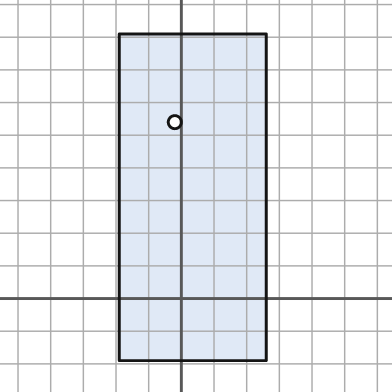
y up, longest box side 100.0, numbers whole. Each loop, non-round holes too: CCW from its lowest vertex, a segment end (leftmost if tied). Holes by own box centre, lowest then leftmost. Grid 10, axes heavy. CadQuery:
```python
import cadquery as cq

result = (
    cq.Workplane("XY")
    .moveTo(-19.0, -19.0)
    .lineTo(26.0, -19.0)
    .lineTo(26.0, 81.0)
    .lineTo(-19.0, 81.0)
    .close()
    .moveTo(-2.0, 54.0)
    .circle(2.0)
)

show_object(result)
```